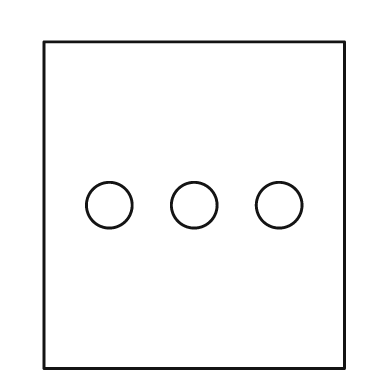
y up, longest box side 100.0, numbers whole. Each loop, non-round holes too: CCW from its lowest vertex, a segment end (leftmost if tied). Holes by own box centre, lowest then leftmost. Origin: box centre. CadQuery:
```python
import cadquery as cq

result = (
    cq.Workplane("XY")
    .moveTo(-46.0, -50.0)
    .lineTo(46.0, -50.0)
    .lineTo(46.0, 50.0)
    .lineTo(-46.0, 50.0)
    .close()
    .moveTo(-26.0, 0.0)
    .circle(7.0)
    .moveTo(0.0, 0.0)
    .circle(7.0)
    .moveTo(26.0, 0.0)
    .circle(7.0)
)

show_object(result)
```